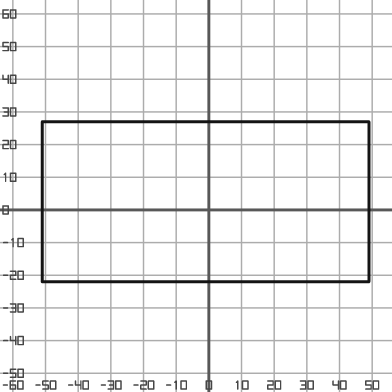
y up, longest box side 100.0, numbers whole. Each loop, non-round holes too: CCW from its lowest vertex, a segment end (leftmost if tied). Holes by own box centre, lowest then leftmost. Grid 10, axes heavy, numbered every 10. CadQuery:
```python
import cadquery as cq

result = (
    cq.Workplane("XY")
    .moveTo(-51.0, -22.0)
    .lineTo(49.0, -22.0)
    .lineTo(49.0, 27.0)
    .lineTo(-51.0, 27.0)
    .close()
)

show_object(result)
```